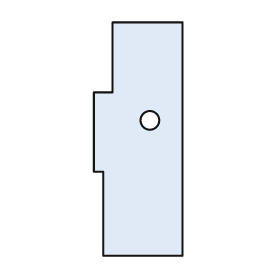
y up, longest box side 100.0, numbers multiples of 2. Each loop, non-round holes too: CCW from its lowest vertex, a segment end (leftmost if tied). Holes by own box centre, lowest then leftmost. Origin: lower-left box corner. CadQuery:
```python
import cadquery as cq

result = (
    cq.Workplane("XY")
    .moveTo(4.0, 0.0)
    .lineTo(38.0, 0.0)
    .lineTo(38.0, 100.0)
    .lineTo(8.0, 100.0)
    .lineTo(8.0, 70.0)
    .lineTo(0.0, 70.0)
    .lineTo(0.0, 36.0)
    .lineTo(4.0, 36.0)
    .close()
    .moveTo(24.0, 58.0)
    .circle(4.0)
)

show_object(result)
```